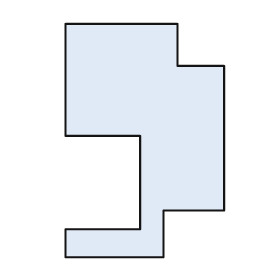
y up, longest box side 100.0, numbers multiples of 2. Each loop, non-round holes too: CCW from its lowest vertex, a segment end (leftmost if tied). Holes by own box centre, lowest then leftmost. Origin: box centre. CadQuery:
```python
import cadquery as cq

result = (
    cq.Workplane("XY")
    .moveTo(-34.0, -50.0)
    .lineTo(8.0, -50.0)
    .lineTo(8.0, -30.0)
    .lineTo(34.0, -30.0)
    .lineTo(34.0, 32.0)
    .lineTo(14.0, 32.0)
    .lineTo(14.0, 50.0)
    .lineTo(-34.0, 50.0)
    .lineTo(-34.0, 2.0)
    .lineTo(-2.0, 2.0)
    .lineTo(-2.0, -38.0)
    .lineTo(-34.0, -38.0)
    .close()
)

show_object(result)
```